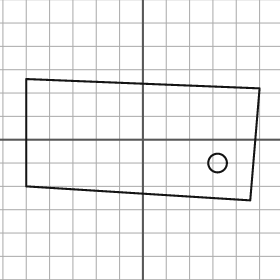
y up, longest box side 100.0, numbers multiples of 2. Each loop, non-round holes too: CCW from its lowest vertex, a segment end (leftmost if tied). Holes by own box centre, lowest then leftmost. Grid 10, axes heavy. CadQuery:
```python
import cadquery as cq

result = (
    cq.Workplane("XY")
    .moveTo(46.0, -26.0)
    .lineTo(50.0, 22.0)
    .lineTo(-50.0, 26.0)
    .lineTo(-50.0, -20.0)
    .close()
    .moveTo(32.0, -10.0)
    .circle(4.0)
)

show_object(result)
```